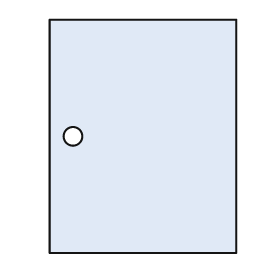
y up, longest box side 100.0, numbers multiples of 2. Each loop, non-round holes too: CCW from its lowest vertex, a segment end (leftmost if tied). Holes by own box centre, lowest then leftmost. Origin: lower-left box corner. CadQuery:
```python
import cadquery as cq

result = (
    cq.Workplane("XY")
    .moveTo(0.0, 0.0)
    .lineTo(80.0, 0.0)
    .lineTo(80.0, 100.0)
    .lineTo(0.0, 100.0)
    .close()
    .moveTo(10.0, 50.0)
    .circle(4.0)
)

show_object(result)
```